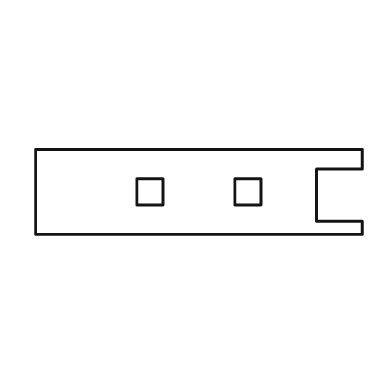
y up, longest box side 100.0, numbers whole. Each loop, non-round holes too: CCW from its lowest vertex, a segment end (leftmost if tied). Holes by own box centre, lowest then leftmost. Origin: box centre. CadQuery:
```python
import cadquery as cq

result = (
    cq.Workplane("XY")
    .moveTo(-50.0, -13.0)
    .lineTo(50.0, -13.0)
    .lineTo(50.0, -9.0)
    .lineTo(36.0, -9.0)
    .lineTo(36.0, 7.0)
    .lineTo(50.0, 7.0)
    .lineTo(50.0, 13.0)
    .lineTo(-50.0, 13.0)
    .close()
    .moveTo(-19.0, -4.0)
    .lineTo(-11.0, -4.0)
    .lineTo(-11.0, 4.0)
    .lineTo(-19.0, 4.0)
    .close()
    .moveTo(11.0, -4.0)
    .lineTo(19.0, -4.0)
    .lineTo(19.0, 4.0)
    .lineTo(11.0, 4.0)
    .close()
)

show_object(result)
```